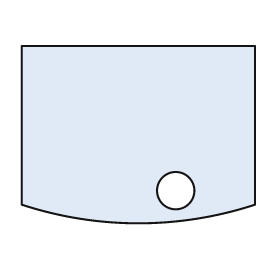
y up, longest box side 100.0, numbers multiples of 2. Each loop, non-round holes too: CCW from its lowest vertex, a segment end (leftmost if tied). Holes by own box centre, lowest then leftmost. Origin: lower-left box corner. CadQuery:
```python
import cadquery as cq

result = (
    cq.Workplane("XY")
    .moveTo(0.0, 8.0)
    .threePointArc((50.0, 0.0), (100.0, 8.0))
    .lineTo(100.0, 76.0)
    .lineTo(0.0, 76.0)
    .close()
    .moveTo(66.0, 14.0)
    .circle(8.0)
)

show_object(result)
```